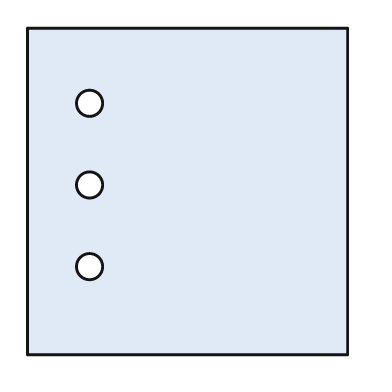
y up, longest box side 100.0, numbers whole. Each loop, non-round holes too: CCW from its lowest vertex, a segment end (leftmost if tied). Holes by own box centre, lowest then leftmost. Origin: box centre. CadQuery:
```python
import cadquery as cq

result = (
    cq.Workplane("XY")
    .moveTo(-49.0, -50.0)
    .lineTo(49.0, -50.0)
    .lineTo(49.0, 50.0)
    .lineTo(-49.0, 50.0)
    .close()
    .moveTo(-30.0, -23.0)
    .circle(4.0)
    .moveTo(-30.0, 2.0)
    .circle(4.0)
    .moveTo(-30.0, 27.0)
    .circle(4.0)
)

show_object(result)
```